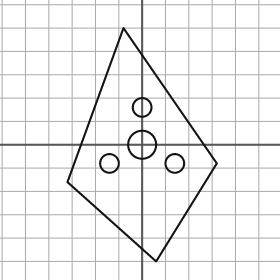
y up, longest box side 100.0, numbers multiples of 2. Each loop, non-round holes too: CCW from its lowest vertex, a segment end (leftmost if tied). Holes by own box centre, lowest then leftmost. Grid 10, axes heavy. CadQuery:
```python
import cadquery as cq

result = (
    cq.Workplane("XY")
    .moveTo(6.0, -50.0)
    .lineTo(32.0, -8.0)
    .lineTo(-8.0, 50.0)
    .lineTo(-32.0, -16.0)
    .close()
    .moveTo(-14.0, -8.0)
    .circle(4.0)
    .moveTo(14.0, -8.0)
    .circle(4.0)
    .moveTo(0.0, 0.0)
    .circle(6.0)
    .moveTo(0.0, 16.0)
    .circle(4.0)
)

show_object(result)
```